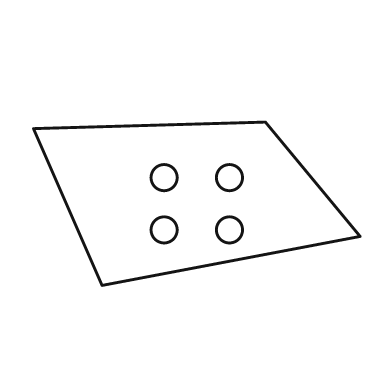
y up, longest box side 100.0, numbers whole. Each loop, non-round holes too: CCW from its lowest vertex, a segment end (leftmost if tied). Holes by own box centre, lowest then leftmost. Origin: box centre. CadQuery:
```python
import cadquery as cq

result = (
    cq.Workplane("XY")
    .moveTo(-29.0, -25.0)
    .lineTo(50.0, -10.0)
    .lineTo(21.0, 25.0)
    .lineTo(-50.0, 23.0)
    .close()
    .moveTo(-10.0, -8.0)
    .circle(4.0)
    .moveTo(10.0, -8.0)
    .circle(4.0)
    .moveTo(-10.0, 8.0)
    .circle(4.0)
    .moveTo(10.0, 8.0)
    .circle(4.0)
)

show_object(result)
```